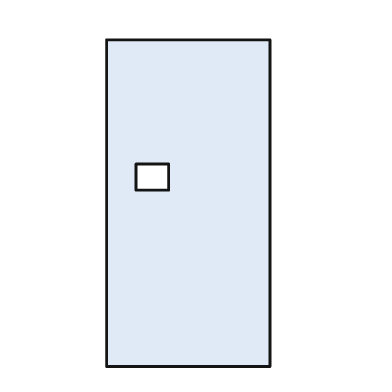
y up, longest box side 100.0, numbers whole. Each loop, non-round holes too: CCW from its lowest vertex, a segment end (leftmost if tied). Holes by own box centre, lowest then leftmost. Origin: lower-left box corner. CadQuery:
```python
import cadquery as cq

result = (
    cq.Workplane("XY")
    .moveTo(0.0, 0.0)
    .lineTo(50.0, 0.0)
    .lineTo(50.0, 100.0)
    .lineTo(0.0, 100.0)
    .close()
    .moveTo(9.0, 54.0)
    .lineTo(19.0, 54.0)
    .lineTo(19.0, 62.0)
    .lineTo(9.0, 62.0)
    .close()
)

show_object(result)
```